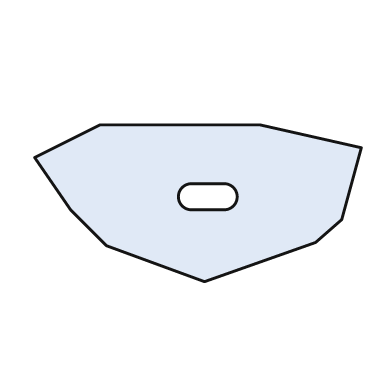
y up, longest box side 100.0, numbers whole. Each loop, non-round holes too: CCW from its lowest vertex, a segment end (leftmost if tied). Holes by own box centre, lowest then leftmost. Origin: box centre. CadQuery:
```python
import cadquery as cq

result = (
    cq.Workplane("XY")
    .moveTo(2.0, -24.0)
    .lineTo(36.0, -12.0)
    .lineTo(44.0, -5.0)
    .lineTo(50.0, 17.0)
    .lineTo(19.0, 24.0)
    .lineTo(-30.0, 24.0)
    .lineTo(-50.0, 14.0)
    .lineTo(-39.0, -2.0)
    .lineTo(-28.0, -13.0)
    .close()
    .moveTo(-2.0, -2.0)
    .lineTo(8.0, -2.0)
    .threePointArc((12.0, 2.0), (8.0, 6.0))
    .lineTo(-2.0, 6.0)
    .threePointArc((-6.0, 2.0), (-2.0, -2.0))
    .close()
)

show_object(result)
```